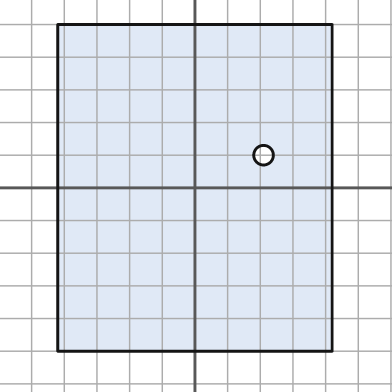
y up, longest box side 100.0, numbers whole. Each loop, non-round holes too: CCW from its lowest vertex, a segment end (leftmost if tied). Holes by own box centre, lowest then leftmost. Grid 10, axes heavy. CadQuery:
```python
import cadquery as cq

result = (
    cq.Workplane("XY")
    .moveTo(-42.0, -50.0)
    .lineTo(42.0, -50.0)
    .lineTo(42.0, 50.0)
    .lineTo(-42.0, 50.0)
    .close()
    .moveTo(21.0, 10.0)
    .circle(3.0)
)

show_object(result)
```